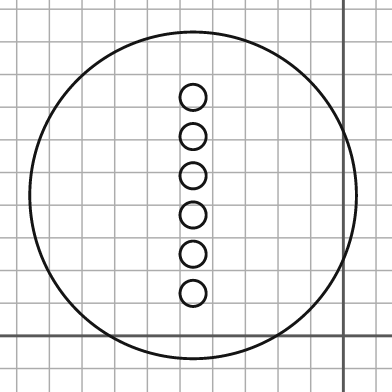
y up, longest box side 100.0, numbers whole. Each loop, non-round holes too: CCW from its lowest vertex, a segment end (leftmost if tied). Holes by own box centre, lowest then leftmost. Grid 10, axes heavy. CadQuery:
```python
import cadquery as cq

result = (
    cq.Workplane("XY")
    .moveTo(-46.0, 43.0)
    .circle(50.0)
    .moveTo(-46.0, 13.0)
    .circle(4.0)
    .moveTo(-46.0, 25.0)
    .circle(4.0)
    .moveTo(-46.0, 37.0)
    .circle(4.0)
    .moveTo(-46.0, 49.0)
    .circle(4.0)
    .moveTo(-46.0, 61.0)
    .circle(4.0)
    .moveTo(-46.0, 73.0)
    .circle(4.0)
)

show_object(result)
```